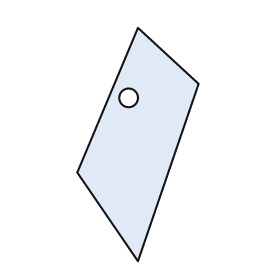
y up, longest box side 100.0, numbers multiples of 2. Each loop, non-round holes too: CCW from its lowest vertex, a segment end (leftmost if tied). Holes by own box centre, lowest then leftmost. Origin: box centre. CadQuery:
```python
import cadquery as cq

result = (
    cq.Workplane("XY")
    .moveTo(0.0, -50.0)
    .lineTo(26.0, 26.0)
    .lineTo(0.0, 50.0)
    .lineTo(-26.0, -12.0)
    .close()
    .moveTo(-4.0, 20.0)
    .circle(4.0)
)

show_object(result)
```